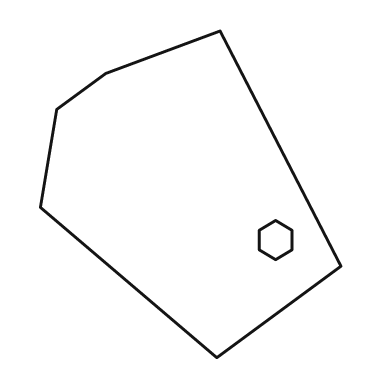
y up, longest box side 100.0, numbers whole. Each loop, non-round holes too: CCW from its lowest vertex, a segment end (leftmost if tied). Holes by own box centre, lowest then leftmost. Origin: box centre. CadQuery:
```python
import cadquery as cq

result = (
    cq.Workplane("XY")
    .moveTo(8.0, -50.0)
    .lineTo(46.0, -22.0)
    .lineTo(9.0, 50.0)
    .lineTo(-26.0, 37.0)
    .lineTo(-41.0, 26.0)
    .lineTo(-46.0, -4.0)
    .close()
    .moveTo(26.0, -20.0)
    .lineTo(31.0, -17.0)
    .lineTo(31.0, -11.0)
    .lineTo(26.0, -8.0)
    .lineTo(21.0, -11.0)
    .lineTo(21.0, -17.0)
    .close()
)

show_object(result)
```